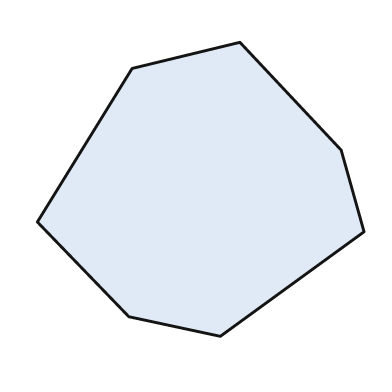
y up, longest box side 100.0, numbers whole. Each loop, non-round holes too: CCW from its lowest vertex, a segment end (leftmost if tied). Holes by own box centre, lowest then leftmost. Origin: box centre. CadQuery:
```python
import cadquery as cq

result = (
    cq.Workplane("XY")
    .moveTo(6.0, -45.0)
    .lineTo(50.0, -13.0)
    .lineTo(43.0, 12.0)
    .lineTo(12.0, 45.0)
    .lineTo(-21.0, 37.0)
    .lineTo(-50.0, -10.0)
    .lineTo(-22.0, -39.0)
    .close()
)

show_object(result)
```